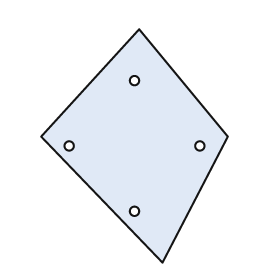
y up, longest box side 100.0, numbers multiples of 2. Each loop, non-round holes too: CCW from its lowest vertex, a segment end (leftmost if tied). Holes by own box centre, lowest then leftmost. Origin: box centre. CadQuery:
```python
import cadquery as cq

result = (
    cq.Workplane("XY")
    .moveTo(12.0, -50.0)
    .lineTo(40.0, 4.0)
    .lineTo(2.0, 50.0)
    .lineTo(-40.0, 4.0)
    .close()
    .moveTo(0.0, -28.0)
    .circle(2.0)
    .moveTo(-28.0, 0.0)
    .circle(2.0)
    .moveTo(28.0, 0.0)
    .circle(2.0)
    .moveTo(0.0, 28.0)
    .circle(2.0)
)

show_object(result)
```